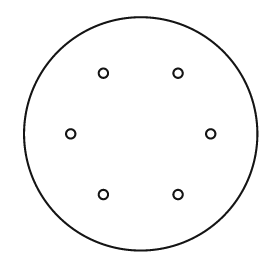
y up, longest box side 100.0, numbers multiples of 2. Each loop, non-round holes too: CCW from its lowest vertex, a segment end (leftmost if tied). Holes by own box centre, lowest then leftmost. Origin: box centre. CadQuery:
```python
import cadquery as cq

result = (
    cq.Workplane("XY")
    .moveTo(0.0, 0.0)
    .circle(50.0)
    .moveTo(-16.0, -26.0)
    .circle(2.0)
    .moveTo(16.0, -26.0)
    .circle(2.0)
    .moveTo(-30.0, 0.0)
    .circle(2.0)
    .moveTo(30.0, 0.0)
    .circle(2.0)
    .moveTo(-16.0, 26.0)
    .circle(2.0)
    .moveTo(16.0, 26.0)
    .circle(2.0)
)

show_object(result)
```